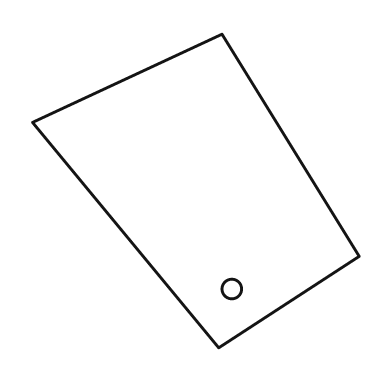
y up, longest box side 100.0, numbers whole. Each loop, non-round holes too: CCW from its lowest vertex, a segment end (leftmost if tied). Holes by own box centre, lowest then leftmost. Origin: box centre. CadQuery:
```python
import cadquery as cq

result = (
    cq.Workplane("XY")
    .moveTo(7.0, -48.0)
    .lineTo(50.0, -20.0)
    .lineTo(8.0, 48.0)
    .lineTo(-50.0, 21.0)
    .close()
    .moveTo(11.0, -30.0)
    .circle(3.0)
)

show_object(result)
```